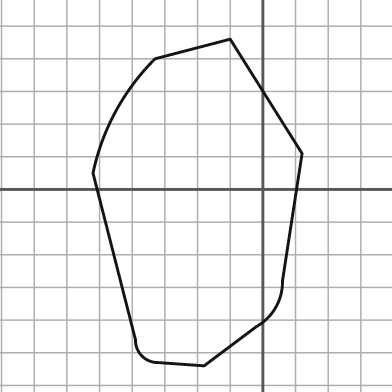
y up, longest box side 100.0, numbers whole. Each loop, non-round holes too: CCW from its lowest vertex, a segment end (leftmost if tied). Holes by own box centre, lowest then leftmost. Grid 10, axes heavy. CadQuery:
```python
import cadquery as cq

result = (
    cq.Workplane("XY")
    .moveTo(-18.0, -54.0)
    .lineTo(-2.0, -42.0)
    .threePointArc((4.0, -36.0), (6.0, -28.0))
    .lineTo(12.0, 11.0)
    .lineTo(-10.0, 46.0)
    .lineTo(-33.0, 40.0)
    .threePointArc((-45.0, 24.0), (-52.0, 5.0))
    .lineTo(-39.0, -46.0)
    .threePointArc((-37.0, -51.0), (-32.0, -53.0))
    .close()
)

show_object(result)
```